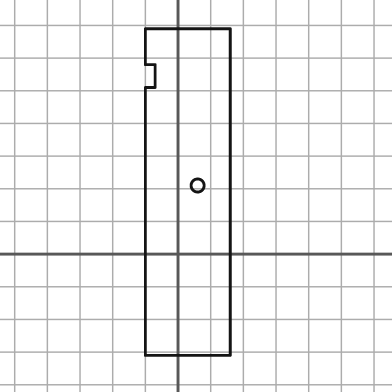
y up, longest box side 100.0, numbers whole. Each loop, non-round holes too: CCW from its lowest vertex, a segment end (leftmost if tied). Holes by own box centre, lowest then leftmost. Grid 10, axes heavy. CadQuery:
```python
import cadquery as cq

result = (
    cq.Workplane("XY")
    .moveTo(-10.0, -31.0)
    .lineTo(16.0, -31.0)
    .lineTo(16.0, 69.0)
    .lineTo(-10.0, 69.0)
    .lineTo(-10.0, 58.0)
    .lineTo(-7.0, 58.0)
    .lineTo(-7.0, 51.0)
    .lineTo(-10.0, 51.0)
    .close()
    .moveTo(6.0, 21.0)
    .circle(2.0)
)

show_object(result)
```